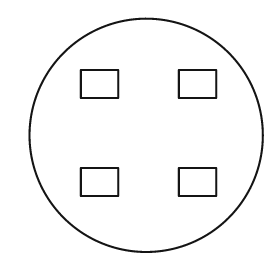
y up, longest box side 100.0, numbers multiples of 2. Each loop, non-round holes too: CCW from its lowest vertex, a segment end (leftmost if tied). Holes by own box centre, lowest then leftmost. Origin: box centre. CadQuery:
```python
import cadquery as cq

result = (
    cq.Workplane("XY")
    .moveTo(0.0, 0.0)
    .circle(50.0)
    .moveTo(-28.0, -26.0)
    .lineTo(-12.0, -26.0)
    .lineTo(-12.0, -14.0)
    .lineTo(-28.0, -14.0)
    .close()
    .moveTo(14.0, -26.0)
    .lineTo(30.0, -26.0)
    .lineTo(30.0, -14.0)
    .lineTo(14.0, -14.0)
    .close()
    .moveTo(-28.0, 16.0)
    .lineTo(-12.0, 16.0)
    .lineTo(-12.0, 28.0)
    .lineTo(-28.0, 28.0)
    .close()
    .moveTo(14.0, 16.0)
    .lineTo(30.0, 16.0)
    .lineTo(30.0, 28.0)
    .lineTo(14.0, 28.0)
    .close()
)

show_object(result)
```